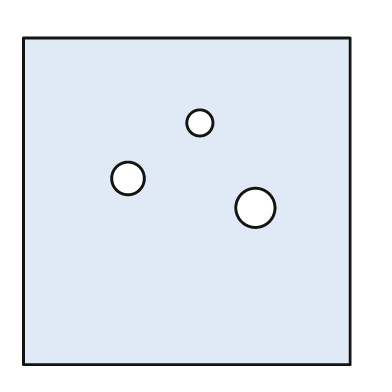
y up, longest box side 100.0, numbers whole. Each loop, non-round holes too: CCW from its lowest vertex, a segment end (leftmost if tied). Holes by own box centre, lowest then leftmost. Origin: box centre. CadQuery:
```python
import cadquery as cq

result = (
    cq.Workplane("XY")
    .moveTo(-50.0, -50.0)
    .lineTo(50.0, -50.0)
    .lineTo(50.0, 50.0)
    .lineTo(-50.0, 50.0)
    .close()
    .moveTo(21.0, -2.0)
    .circle(6.0)
    .moveTo(-18.0, 7.0)
    .circle(5.0)
    .moveTo(4.0, 24.0)
    .circle(4.0)
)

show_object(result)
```